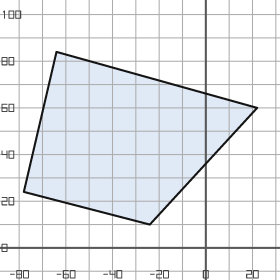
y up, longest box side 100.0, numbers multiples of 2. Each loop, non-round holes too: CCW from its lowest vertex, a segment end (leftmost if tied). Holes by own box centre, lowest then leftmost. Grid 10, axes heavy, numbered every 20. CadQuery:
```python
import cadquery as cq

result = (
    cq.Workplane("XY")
    .moveTo(-24.0, 10.0)
    .lineTo(22.0, 60.0)
    .lineTo(-64.0, 84.0)
    .lineTo(-78.0, 24.0)
    .close()
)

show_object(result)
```